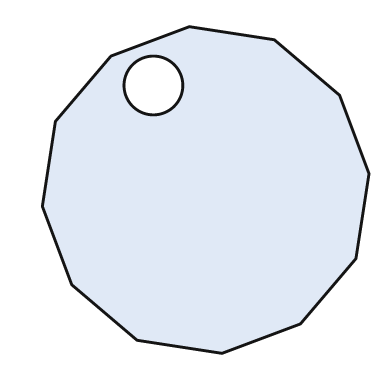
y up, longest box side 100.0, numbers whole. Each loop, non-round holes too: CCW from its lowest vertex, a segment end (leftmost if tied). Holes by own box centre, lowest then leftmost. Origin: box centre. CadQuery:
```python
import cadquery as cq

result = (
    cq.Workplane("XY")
    .moveTo(5.0, -50.0)
    .lineTo(29.0, -41.0)
    .lineTo(46.0, -21.0)
    .lineTo(50.0, 5.0)
    .lineTo(41.0, 29.0)
    .lineTo(21.0, 46.0)
    .lineTo(-5.0, 50.0)
    .lineTo(-29.0, 41.0)
    .lineTo(-46.0, 21.0)
    .lineTo(-50.0, -5.0)
    .lineTo(-41.0, -29.0)
    .lineTo(-21.0, -46.0)
    .close()
    .moveTo(-16.0, 32.0)
    .circle(9.0)
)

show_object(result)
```